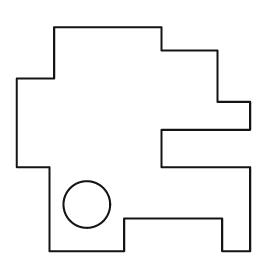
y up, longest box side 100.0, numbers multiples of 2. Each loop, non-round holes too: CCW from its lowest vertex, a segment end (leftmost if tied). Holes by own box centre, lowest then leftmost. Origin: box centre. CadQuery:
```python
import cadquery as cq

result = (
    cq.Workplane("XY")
    .moveTo(-36.0, -48.0)
    .lineTo(-4.0, -48.0)
    .lineTo(-4.0, -34.0)
    .lineTo(38.0, -34.0)
    .lineTo(38.0, -48.0)
    .lineTo(50.0, -48.0)
    .lineTo(50.0, -12.0)
    .lineTo(12.0, -12.0)
    .lineTo(12.0, 4.0)
    .lineTo(50.0, 4.0)
    .lineTo(50.0, 16.0)
    .lineTo(36.0, 16.0)
    .lineTo(36.0, 38.0)
    .lineTo(12.0, 38.0)
    .lineTo(12.0, 48.0)
    .lineTo(-34.0, 48.0)
    .lineTo(-34.0, 26.0)
    .lineTo(-50.0, 26.0)
    .lineTo(-50.0, -12.0)
    .lineTo(-36.0, -12.0)
    .close()
    .moveTo(-20.0, -28.0)
    .circle(10.0)
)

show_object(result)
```